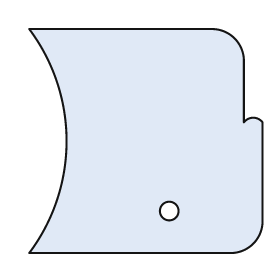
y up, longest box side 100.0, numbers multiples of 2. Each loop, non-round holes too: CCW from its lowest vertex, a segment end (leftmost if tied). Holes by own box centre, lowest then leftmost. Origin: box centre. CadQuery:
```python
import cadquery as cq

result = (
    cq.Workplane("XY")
    .moveTo(-50.0, -48.0)
    .lineTo(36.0, -48.0)
    .threePointArc((46.0, -44.0), (50.0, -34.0))
    .lineTo(50.0, 8.0)
    .threePointArc((46.0, 10.0), (42.0, 8.0))
    .lineTo(42.0, 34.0)
    .threePointArc((38.0, 44.0), (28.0, 48.0))
    .lineTo(-50.0, 48.0)
    .threePointArc((-34.0, 0.0), (-50.0, -48.0))
    .close()
    .moveTo(10.0, -30.0)
    .circle(4.0)
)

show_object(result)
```